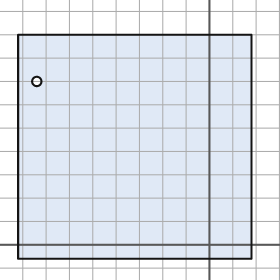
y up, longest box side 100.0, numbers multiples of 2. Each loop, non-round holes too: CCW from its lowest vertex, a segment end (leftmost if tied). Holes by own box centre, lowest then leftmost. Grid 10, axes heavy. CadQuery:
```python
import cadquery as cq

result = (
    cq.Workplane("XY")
    .moveTo(-82.0, -6.0)
    .lineTo(18.0, -6.0)
    .lineTo(18.0, 90.0)
    .lineTo(-82.0, 90.0)
    .close()
    .moveTo(-74.0, 70.0)
    .circle(2.0)
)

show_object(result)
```